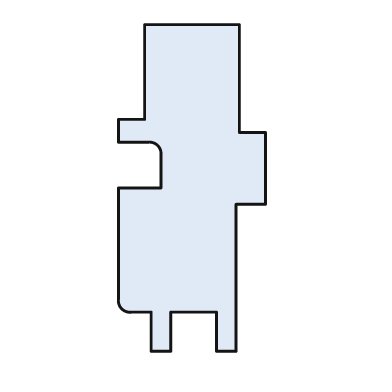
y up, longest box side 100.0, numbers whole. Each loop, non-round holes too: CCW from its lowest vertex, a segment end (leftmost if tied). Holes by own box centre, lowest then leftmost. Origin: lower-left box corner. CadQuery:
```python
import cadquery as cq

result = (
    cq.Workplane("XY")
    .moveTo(10.0, 0.0)
    .lineTo(16.0, 0.0)
    .lineTo(16.0, 12.0)
    .lineTo(30.0, 12.0)
    .lineTo(30.0, 0.0)
    .lineTo(36.0, 0.0)
    .lineTo(36.0, 45.0)
    .lineTo(45.0, 45.0)
    .lineTo(45.0, 67.0)
    .lineTo(37.0, 67.0)
    .lineTo(37.0, 100.0)
    .lineTo(8.0, 100.0)
    .lineTo(8.0, 71.0)
    .lineTo(0.0, 71.0)
    .lineTo(0.0, 64.0)
    .lineTo(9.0, 64.0)
    .threePointArc((12.0, 63.0), (13.0, 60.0))
    .lineTo(13.0, 50.0)
    .lineTo(0.0, 50.0)
    .lineTo(0.0, 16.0)
    .threePointArc((1.0, 13.0), (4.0, 12.0))
    .lineTo(10.0, 12.0)
    .close()
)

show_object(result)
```